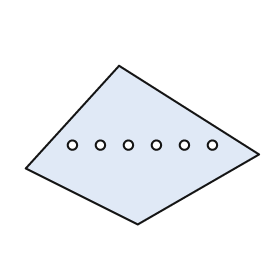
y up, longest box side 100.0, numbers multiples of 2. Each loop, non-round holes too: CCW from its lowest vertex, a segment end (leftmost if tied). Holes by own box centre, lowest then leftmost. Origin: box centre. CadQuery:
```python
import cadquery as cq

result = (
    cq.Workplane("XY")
    .moveTo(-2.0, -34.0)
    .lineTo(50.0, -4.0)
    .lineTo(-10.0, 34.0)
    .lineTo(-50.0, -10.0)
    .close()
    .moveTo(-30.0, 0.0)
    .circle(2.0)
    .moveTo(-18.0, 0.0)
    .circle(2.0)
    .moveTo(-6.0, 0.0)
    .circle(2.0)
    .moveTo(6.0, 0.0)
    .circle(2.0)
    .moveTo(18.0, 0.0)
    .circle(2.0)
    .moveTo(30.0, 0.0)
    .circle(2.0)
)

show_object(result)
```